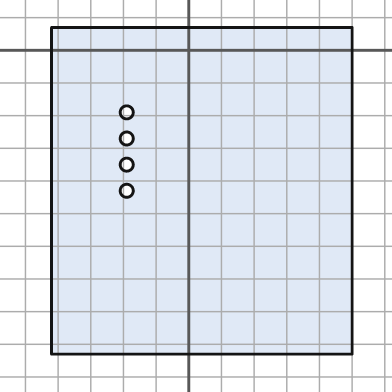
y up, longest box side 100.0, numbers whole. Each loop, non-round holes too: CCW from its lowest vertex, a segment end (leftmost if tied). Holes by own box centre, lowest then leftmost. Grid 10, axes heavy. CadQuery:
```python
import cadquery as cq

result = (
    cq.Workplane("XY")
    .moveTo(-42.0, -93.0)
    .lineTo(50.0, -93.0)
    .lineTo(50.0, 7.0)
    .lineTo(-42.0, 7.0)
    .close()
    .moveTo(-19.0, -43.0)
    .circle(2.0)
    .moveTo(-19.0, -35.0)
    .circle(2.0)
    .moveTo(-19.0, -27.0)
    .circle(2.0)
    .moveTo(-19.0, -19.0)
    .circle(2.0)
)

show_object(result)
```